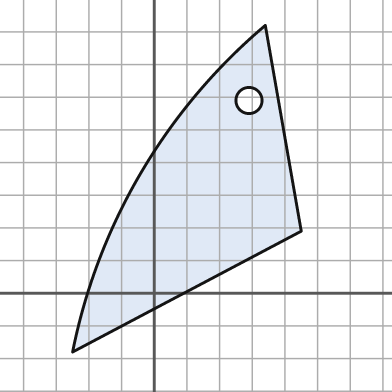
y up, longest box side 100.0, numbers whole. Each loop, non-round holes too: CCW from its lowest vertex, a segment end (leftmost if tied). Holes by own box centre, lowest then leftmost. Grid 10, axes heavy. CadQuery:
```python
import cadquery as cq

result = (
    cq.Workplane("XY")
    .moveTo(-25.0, -18.0)
    .lineTo(45.0, 19.0)
    .lineTo(34.0, 82.0)
    .threePointArc((-4.0, 37.0), (-25.0, -18.0))
    .close()
    .moveTo(29.0, 59.0)
    .circle(4.0)
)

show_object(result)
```